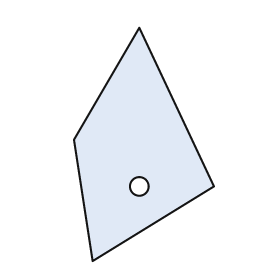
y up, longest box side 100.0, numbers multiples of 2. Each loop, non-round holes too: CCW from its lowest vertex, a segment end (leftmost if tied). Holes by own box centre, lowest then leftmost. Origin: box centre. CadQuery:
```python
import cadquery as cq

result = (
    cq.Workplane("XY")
    .moveTo(-22.0, -50.0)
    .lineTo(30.0, -18.0)
    .lineTo(-2.0, 50.0)
    .lineTo(-30.0, 2.0)
    .close()
    .moveTo(-2.0, -18.0)
    .circle(4.0)
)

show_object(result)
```